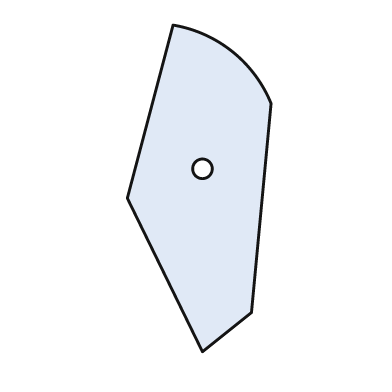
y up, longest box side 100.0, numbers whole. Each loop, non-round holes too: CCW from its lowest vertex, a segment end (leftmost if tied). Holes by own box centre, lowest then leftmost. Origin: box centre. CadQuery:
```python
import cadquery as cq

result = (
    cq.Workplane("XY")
    .moveTo(1.0, -50.0)
    .lineTo(16.0, -38.0)
    .lineTo(22.0, 26.0)
    .threePointArc((10.0, 42.0), (-8.0, 50.0))
    .lineTo(-22.0, -3.0)
    .close()
    .moveTo(1.0, 6.0)
    .circle(3.0)
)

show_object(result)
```